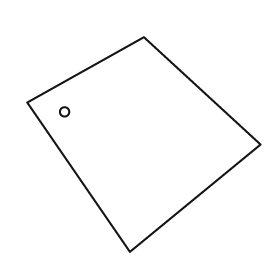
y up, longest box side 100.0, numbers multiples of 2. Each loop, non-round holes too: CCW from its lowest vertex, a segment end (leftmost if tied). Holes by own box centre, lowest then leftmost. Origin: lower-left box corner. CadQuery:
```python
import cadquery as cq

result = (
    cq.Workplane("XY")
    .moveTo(44.0, 0.0)
    .lineTo(100.0, 46.0)
    .lineTo(50.0, 92.0)
    .lineTo(0.0, 64.0)
    .close()
    .moveTo(16.0, 60.0)
    .circle(2.0)
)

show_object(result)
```